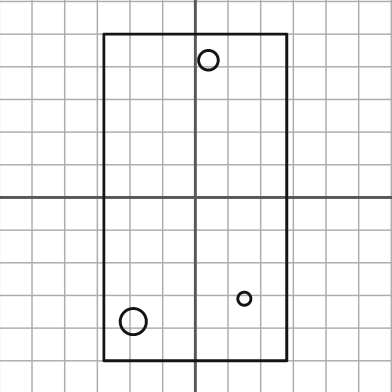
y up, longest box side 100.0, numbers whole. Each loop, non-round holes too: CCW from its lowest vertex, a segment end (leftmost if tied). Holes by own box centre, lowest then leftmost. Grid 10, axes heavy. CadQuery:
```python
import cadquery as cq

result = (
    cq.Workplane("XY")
    .moveTo(-28.0, -50.0)
    .lineTo(28.0, -50.0)
    .lineTo(28.0, 50.0)
    .lineTo(-28.0, 50.0)
    .close()
    .moveTo(-19.0, -38.0)
    .circle(4.0)
    .moveTo(15.0, -31.0)
    .circle(2.0)
    .moveTo(4.0, 42.0)
    .circle(3.0)
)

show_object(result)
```